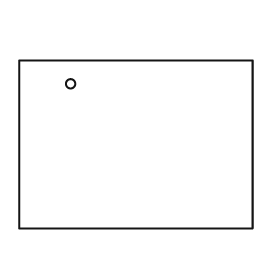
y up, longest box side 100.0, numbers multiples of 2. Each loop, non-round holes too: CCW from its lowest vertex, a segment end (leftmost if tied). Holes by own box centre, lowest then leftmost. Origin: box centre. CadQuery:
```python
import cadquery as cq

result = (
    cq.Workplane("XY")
    .moveTo(-50.0, -36.0)
    .lineTo(50.0, -36.0)
    .lineTo(50.0, 36.0)
    .lineTo(-50.0, 36.0)
    .close()
    .moveTo(-28.0, 26.0)
    .circle(2.0)
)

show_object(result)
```